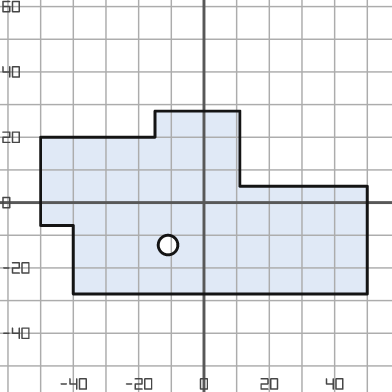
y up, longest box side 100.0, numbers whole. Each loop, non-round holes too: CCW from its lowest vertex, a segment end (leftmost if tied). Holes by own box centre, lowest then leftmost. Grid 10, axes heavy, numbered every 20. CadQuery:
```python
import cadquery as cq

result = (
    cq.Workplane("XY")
    .moveTo(-40.0, -28.0)
    .lineTo(50.0, -28.0)
    .lineTo(50.0, 5.0)
    .lineTo(11.0, 5.0)
    .lineTo(11.0, 28.0)
    .lineTo(-15.0, 28.0)
    .lineTo(-15.0, 20.0)
    .lineTo(-50.0, 20.0)
    .lineTo(-50.0, -7.0)
    .lineTo(-40.0, -7.0)
    .close()
    .moveTo(-11.0, -13.0)
    .circle(3.0)
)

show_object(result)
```